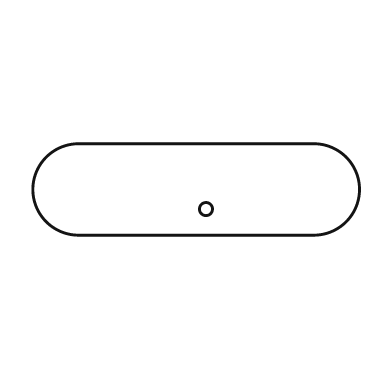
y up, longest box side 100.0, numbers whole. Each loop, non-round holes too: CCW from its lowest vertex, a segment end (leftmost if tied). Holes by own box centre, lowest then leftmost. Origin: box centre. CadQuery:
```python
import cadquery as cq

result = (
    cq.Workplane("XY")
    .moveTo(-36.0, -14.0)
    .lineTo(36.0, -14.0)
    .threePointArc((50.0, 0.0), (36.0, 14.0))
    .lineTo(-36.0, 14.0)
    .threePointArc((-50.0, 0.0), (-36.0, -14.0))
    .close()
    .moveTo(3.0, -6.0)
    .circle(2.0)
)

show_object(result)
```